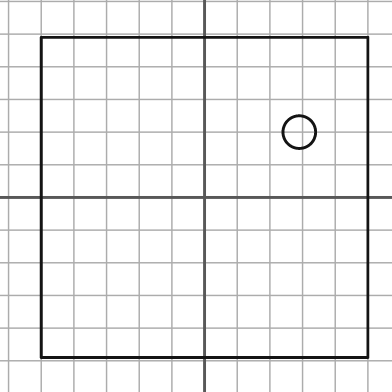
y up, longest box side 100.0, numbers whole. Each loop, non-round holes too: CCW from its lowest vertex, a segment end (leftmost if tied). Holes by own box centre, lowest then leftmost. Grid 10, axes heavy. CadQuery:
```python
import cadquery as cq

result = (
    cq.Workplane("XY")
    .moveTo(-50.0, -49.0)
    .lineTo(50.0, -49.0)
    .lineTo(50.0, 49.0)
    .lineTo(-50.0, 49.0)
    .close()
    .moveTo(29.0, 20.0)
    .circle(5.0)
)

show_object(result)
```